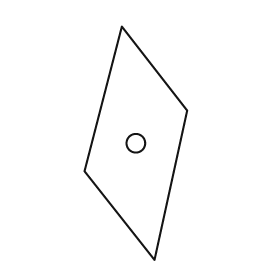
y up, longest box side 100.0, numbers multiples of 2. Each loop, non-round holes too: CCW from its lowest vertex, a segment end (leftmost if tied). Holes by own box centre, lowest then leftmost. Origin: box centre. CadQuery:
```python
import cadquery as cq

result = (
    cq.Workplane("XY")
    .moveTo(8.0, -50.0)
    .lineTo(22.0, 14.0)
    .lineTo(-6.0, 50.0)
    .lineTo(-22.0, -12.0)
    .close()
    .moveTo(0.0, 0.0)
    .circle(4.0)
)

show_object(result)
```